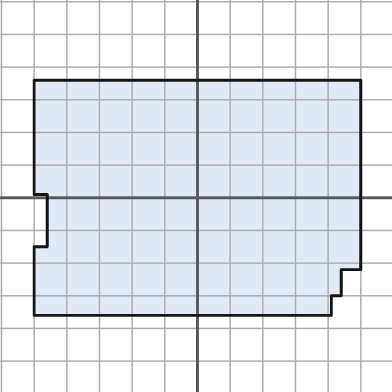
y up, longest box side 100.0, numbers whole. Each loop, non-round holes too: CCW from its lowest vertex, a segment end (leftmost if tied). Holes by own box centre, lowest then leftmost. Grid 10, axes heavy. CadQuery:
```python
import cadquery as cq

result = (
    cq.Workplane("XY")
    .moveTo(-50.0, -36.0)
    .lineTo(41.0, -36.0)
    .lineTo(41.0, -30.0)
    .lineTo(44.0, -30.0)
    .lineTo(44.0, -22.0)
    .lineTo(50.0, -22.0)
    .lineTo(50.0, 36.0)
    .lineTo(-50.0, 36.0)
    .lineTo(-50.0, 1.0)
    .lineTo(-46.0, 1.0)
    .lineTo(-46.0, -15.0)
    .lineTo(-50.0, -15.0)
    .close()
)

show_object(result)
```